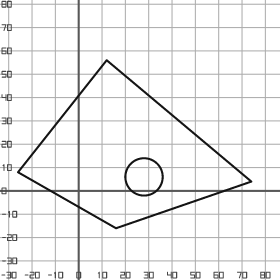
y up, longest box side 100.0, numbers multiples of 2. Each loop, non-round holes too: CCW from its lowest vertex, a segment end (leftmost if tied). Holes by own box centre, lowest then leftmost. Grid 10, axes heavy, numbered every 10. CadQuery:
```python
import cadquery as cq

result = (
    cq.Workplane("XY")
    .moveTo(16.0, -16.0)
    .lineTo(74.0, 4.0)
    .lineTo(12.0, 56.0)
    .lineTo(-26.0, 8.0)
    .close()
    .moveTo(28.0, 6.0)
    .circle(8.0)
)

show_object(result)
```